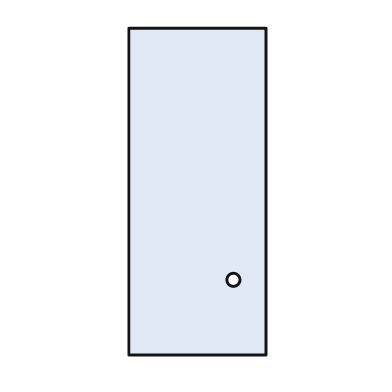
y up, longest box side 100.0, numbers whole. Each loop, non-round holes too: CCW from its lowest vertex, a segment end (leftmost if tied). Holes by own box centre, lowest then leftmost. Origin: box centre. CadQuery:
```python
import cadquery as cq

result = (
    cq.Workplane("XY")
    .moveTo(-21.0, -50.0)
    .lineTo(21.0, -50.0)
    .lineTo(21.0, 50.0)
    .lineTo(-21.0, 50.0)
    .close()
    .moveTo(11.0, -27.0)
    .circle(2.0)
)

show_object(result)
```